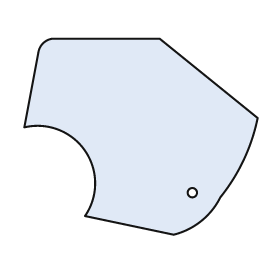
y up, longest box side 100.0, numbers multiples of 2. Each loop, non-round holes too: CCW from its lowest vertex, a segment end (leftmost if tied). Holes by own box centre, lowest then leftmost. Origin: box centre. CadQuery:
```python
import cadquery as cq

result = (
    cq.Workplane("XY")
    .moveTo(14.0, -42.0)
    .threePointArc((26.0, -36.0), (34.0, -26.0))
    .threePointArc((44.0, -10.0), (50.0, 8.0))
    .lineTo(8.0, 42.0)
    .lineTo(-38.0, 42.0)
    .threePointArc((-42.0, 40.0), (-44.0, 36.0))
    .lineTo(-50.0, 4.0)
    .threePointArc((-24.0, -6.0), (-24.0, -34.0))
    .close()
    .moveTo(22.0, -24.0)
    .circle(2.0)
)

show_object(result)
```